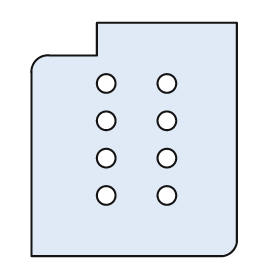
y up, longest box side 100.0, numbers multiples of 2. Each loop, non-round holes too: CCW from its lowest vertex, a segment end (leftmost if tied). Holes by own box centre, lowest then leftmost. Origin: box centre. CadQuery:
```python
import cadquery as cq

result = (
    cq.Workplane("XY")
    .moveTo(-44.0, -50.0)
    .lineTo(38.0, -50.0)
    .threePointArc((42.0, -48.0), (44.0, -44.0))
    .lineTo(44.0, 50.0)
    .lineTo(-16.0, 50.0)
    .lineTo(-16.0, 36.0)
    .lineTo(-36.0, 36.0)
    .threePointArc((-42.0, 34.0), (-44.0, 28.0))
    .close()
    .moveTo(-12.0, -24.0)
    .circle(4.0)
    .moveTo(14.0, -24.0)
    .circle(4.0)
    .moveTo(-12.0, -8.0)
    .circle(4.0)
    .moveTo(14.0, -8.0)
    .circle(4.0)
    .moveTo(-12.0, 8.0)
    .circle(4.0)
    .moveTo(14.0, 8.0)
    .circle(4.0)
    .moveTo(-12.0, 24.0)
    .circle(4.0)
    .moveTo(14.0, 24.0)
    .circle(4.0)
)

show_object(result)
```